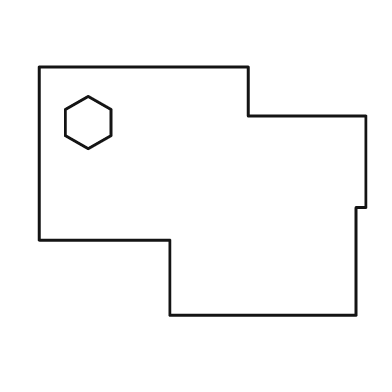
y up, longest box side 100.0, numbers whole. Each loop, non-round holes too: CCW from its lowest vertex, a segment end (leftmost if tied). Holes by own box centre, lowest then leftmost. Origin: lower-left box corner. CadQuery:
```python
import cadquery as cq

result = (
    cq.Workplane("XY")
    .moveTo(40.0, 0.0)
    .lineTo(97.0, 0.0)
    .lineTo(97.0, 33.0)
    .lineTo(100.0, 33.0)
    .lineTo(100.0, 61.0)
    .lineTo(64.0, 61.0)
    .lineTo(64.0, 76.0)
    .lineTo(0.0, 76.0)
    .lineTo(0.0, 23.0)
    .lineTo(40.0, 23.0)
    .close()
    .moveTo(15.0, 51.0)
    .lineTo(22.0, 55.0)
    .lineTo(22.0, 63.0)
    .lineTo(15.0, 67.0)
    .lineTo(8.0, 63.0)
    .lineTo(8.0, 55.0)
    .close()
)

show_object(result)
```